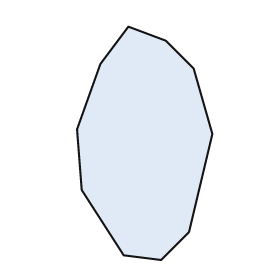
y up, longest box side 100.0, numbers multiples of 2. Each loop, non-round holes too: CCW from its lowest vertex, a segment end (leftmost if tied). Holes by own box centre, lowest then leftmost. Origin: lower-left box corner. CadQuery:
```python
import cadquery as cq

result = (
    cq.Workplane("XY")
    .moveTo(36.0, 0.0)
    .lineTo(48.0, 12.0)
    .lineTo(58.0, 54.0)
    .lineTo(50.0, 82.0)
    .lineTo(38.0, 94.0)
    .lineTo(22.0, 100.0)
    .lineTo(10.0, 84.0)
    .lineTo(0.0, 56.0)
    .lineTo(2.0, 30.0)
    .lineTo(20.0, 2.0)
    .close()
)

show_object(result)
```